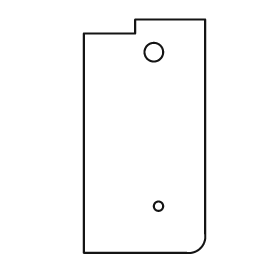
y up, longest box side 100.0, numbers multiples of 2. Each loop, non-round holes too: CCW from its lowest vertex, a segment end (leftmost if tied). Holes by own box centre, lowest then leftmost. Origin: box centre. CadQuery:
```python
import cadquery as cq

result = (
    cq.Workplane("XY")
    .moveTo(-26.0, -50.0)
    .lineTo(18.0, -50.0)
    .threePointArc((24.0, -48.0), (26.0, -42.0))
    .lineTo(26.0, 50.0)
    .lineTo(-4.0, 50.0)
    .lineTo(-4.0, 44.0)
    .lineTo(-26.0, 44.0)
    .close()
    .moveTo(6.0, -30.0)
    .circle(2.0)
    .moveTo(4.0, 36.0)
    .circle(4.0)
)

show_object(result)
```